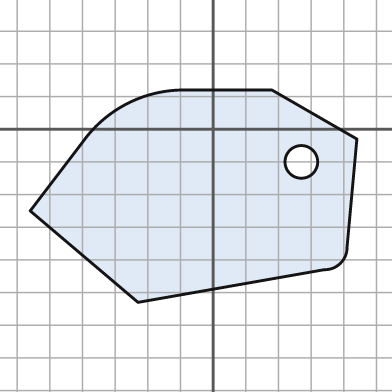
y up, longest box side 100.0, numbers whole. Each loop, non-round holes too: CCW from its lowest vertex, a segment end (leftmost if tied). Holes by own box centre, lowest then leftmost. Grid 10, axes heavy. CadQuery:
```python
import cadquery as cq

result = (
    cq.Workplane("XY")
    .moveTo(-23.0, -53.0)
    .lineTo(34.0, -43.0)
    .threePointArc((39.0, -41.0), (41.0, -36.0))
    .lineTo(44.0, -3.0)
    .lineTo(18.0, 12.0)
    .lineTo(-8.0, 12.0)
    .threePointArc((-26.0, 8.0), (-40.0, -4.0))
    .lineTo(-56.0, -25.0)
    .close()
    .moveTo(27.0, -10.0)
    .circle(5.0)
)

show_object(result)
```